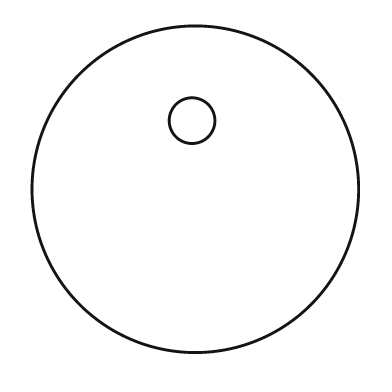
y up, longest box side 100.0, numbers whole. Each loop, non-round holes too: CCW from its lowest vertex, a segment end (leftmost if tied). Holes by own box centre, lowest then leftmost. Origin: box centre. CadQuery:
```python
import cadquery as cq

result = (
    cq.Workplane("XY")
    .moveTo(0.0, 0.0)
    .circle(50.0)
    .moveTo(-1.0, 21.0)
    .circle(7.0)
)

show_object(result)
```